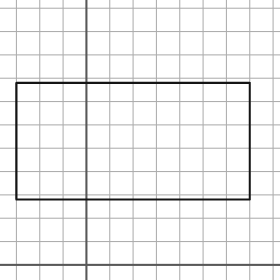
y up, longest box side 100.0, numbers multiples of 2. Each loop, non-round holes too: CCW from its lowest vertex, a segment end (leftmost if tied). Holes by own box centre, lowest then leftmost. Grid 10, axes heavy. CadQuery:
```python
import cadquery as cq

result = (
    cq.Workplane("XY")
    .moveTo(-30.0, 28.0)
    .lineTo(70.0, 28.0)
    .lineTo(70.0, 78.0)
    .lineTo(-30.0, 78.0)
    .close()
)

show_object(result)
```